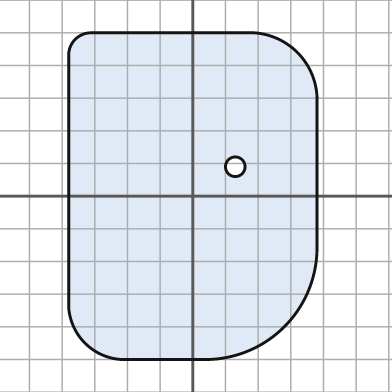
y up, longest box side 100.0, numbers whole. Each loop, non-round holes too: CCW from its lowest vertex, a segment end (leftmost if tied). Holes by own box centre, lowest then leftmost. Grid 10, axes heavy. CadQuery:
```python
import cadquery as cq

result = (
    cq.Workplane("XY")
    .moveTo(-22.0, -50.0)
    .lineTo(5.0, -50.0)
    .threePointArc((28.0, -40.0), (38.0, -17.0))
    .lineTo(38.0, 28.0)
    .threePointArc((32.0, 44.0), (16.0, 50.0))
    .lineTo(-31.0, 50.0)
    .threePointArc((-36.0, 48.0), (-38.0, 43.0))
    .lineTo(-38.0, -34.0)
    .threePointArc((-33.0, -45.0), (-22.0, -50.0))
    .close()
    .moveTo(13.0, 9.0)
    .circle(3.0)
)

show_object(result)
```